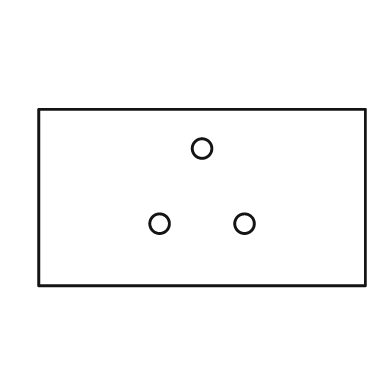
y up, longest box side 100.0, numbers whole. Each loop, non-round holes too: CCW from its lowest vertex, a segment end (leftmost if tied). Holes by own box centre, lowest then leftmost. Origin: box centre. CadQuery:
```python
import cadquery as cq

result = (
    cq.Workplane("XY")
    .moveTo(-50.0, -27.0)
    .lineTo(50.0, -27.0)
    .lineTo(50.0, 27.0)
    .lineTo(-50.0, 27.0)
    .close()
    .moveTo(-13.0, -8.0)
    .circle(3.0)
    .moveTo(13.0, -8.0)
    .circle(3.0)
    .moveTo(0.0, 15.0)
    .circle(3.0)
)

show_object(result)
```